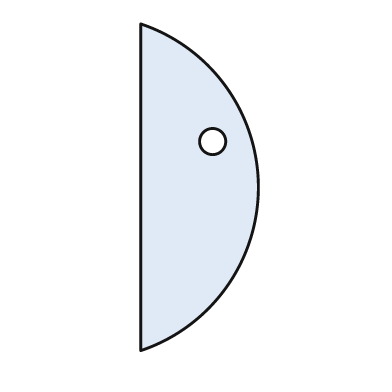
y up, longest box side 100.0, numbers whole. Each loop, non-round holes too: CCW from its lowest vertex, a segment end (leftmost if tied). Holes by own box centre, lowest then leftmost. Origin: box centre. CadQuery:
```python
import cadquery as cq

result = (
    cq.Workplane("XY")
    .moveTo(-18.0, -50.0)
    .threePointArc((18.0, 0.0), (-18.0, 50.0))
    .close()
    .moveTo(4.0, 14.0)
    .circle(4.0)
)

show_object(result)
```